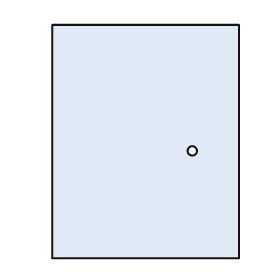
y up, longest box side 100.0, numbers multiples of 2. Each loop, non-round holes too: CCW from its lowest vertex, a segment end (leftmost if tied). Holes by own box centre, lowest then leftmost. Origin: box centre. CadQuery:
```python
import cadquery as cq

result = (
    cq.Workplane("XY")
    .moveTo(-40.0, -50.0)
    .lineTo(40.0, -50.0)
    .lineTo(40.0, 50.0)
    .lineTo(-40.0, 50.0)
    .close()
    .moveTo(20.0, -4.0)
    .circle(2.0)
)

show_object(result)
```